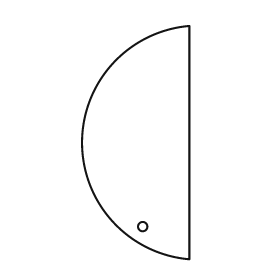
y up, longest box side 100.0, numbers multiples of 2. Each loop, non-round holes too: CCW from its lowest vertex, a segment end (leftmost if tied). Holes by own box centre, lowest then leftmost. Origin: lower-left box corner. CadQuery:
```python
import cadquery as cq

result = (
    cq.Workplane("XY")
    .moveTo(46.0, 0.0)
    .lineTo(46.0, 100.0)
    .threePointArc((0.0, 50.0), (46.0, 0.0))
    .close()
    .moveTo(26.0, 14.0)
    .circle(2.0)
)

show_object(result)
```